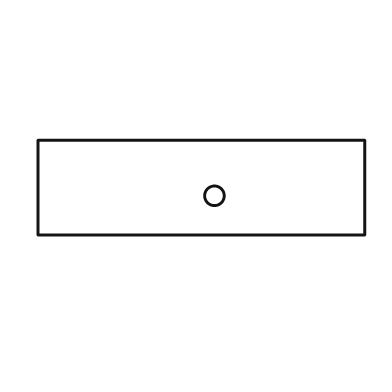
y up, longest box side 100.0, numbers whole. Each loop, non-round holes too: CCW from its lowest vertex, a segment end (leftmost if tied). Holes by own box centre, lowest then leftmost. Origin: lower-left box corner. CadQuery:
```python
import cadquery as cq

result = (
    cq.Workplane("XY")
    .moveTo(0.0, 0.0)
    .lineTo(100.0, 0.0)
    .lineTo(100.0, 29.0)
    .lineTo(0.0, 29.0)
    .close()
    .moveTo(54.0, 12.0)
    .circle(3.0)
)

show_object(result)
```